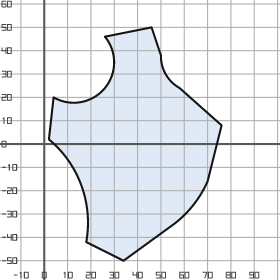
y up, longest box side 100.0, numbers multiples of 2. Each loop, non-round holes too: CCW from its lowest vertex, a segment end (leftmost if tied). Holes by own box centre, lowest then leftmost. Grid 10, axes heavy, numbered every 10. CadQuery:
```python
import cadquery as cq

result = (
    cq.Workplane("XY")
    .moveTo(34.0, -50.0)
    .lineTo(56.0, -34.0)
    .threePointArc((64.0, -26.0), (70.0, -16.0))
    .lineTo(76.0, 8.0)
    .lineTo(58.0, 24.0)
    .threePointArc((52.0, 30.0), (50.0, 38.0))
    .lineTo(46.0, 50.0)
    .lineTo(26.0, 46.0)
    .threePointArc((26.0, 24.0), (4.0, 20.0))
    .lineTo(2.0, 2.0)
    .threePointArc((16.0, -18.0), (18.0, -42.0))
    .close()
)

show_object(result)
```